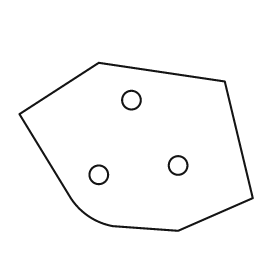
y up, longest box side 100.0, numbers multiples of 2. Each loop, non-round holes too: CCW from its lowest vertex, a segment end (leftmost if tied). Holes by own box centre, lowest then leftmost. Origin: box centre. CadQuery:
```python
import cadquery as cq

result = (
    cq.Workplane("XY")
    .moveTo(18.0, -36.0)
    .lineTo(50.0, -22.0)
    .lineTo(38.0, 28.0)
    .lineTo(-16.0, 36.0)
    .lineTo(-50.0, 14.0)
    .lineTo(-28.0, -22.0)
    .threePointArc((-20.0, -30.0), (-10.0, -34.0))
    .close()
    .moveTo(-16.0, -12.0)
    .circle(4.0)
    .moveTo(18.0, -8.0)
    .circle(4.0)
    .moveTo(-2.0, 20.0)
    .circle(4.0)
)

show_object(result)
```